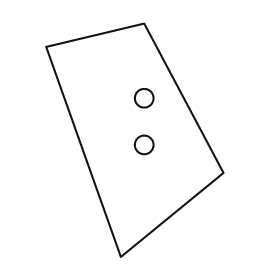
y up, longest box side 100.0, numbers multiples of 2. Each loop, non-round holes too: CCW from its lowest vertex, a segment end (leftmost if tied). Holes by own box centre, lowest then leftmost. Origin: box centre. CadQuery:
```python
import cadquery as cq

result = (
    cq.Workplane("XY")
    .moveTo(-6.0, -50.0)
    .lineTo(38.0, -14.0)
    .lineTo(4.0, 50.0)
    .lineTo(-38.0, 40.0)
    .close()
    .moveTo(4.0, -2.0)
    .circle(4.0)
    .moveTo(4.0, 18.0)
    .circle(4.0)
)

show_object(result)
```